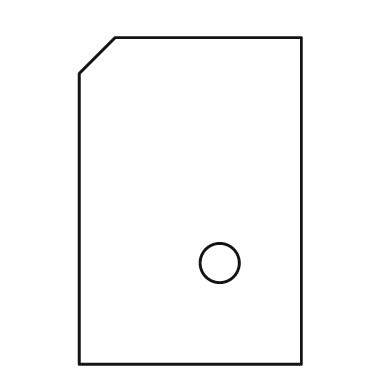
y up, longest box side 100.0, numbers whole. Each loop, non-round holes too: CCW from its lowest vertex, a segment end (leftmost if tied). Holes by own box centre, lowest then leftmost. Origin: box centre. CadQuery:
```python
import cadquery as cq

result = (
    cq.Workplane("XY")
    .moveTo(-34.0, -50.0)
    .lineTo(34.0, -50.0)
    .lineTo(34.0, 50.0)
    .lineTo(-23.0, 50.0)
    .lineTo(-34.0, 39.0)
    .close()
    .moveTo(9.0, -19.0)
    .circle(6.0)
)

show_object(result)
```